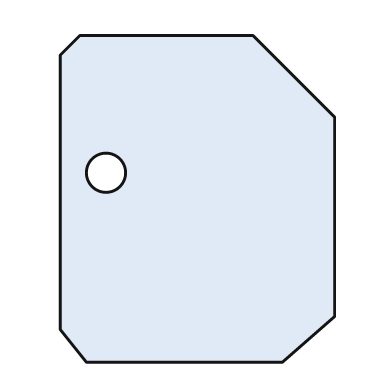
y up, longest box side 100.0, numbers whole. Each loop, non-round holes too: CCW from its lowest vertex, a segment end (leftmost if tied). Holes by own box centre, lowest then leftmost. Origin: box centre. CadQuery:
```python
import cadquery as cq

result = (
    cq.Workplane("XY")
    .moveTo(-34.0, -50.0)
    .lineTo(26.0, -50.0)
    .lineTo(42.0, -36.0)
    .lineTo(42.0, 25.0)
    .lineTo(17.0, 50.0)
    .lineTo(-36.0, 50.0)
    .lineTo(-42.0, 44.0)
    .lineTo(-42.0, -40.0)
    .close()
    .moveTo(-28.0, 8.0)
    .circle(6.0)
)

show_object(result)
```